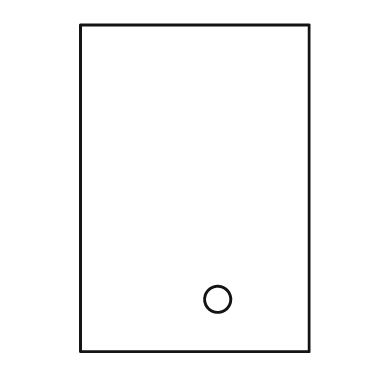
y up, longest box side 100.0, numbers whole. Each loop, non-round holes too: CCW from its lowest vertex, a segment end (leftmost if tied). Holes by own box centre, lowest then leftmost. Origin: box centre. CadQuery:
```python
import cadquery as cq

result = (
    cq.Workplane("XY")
    .moveTo(-35.0, -50.0)
    .lineTo(35.0, -50.0)
    .lineTo(35.0, 50.0)
    .lineTo(-35.0, 50.0)
    .close()
    .moveTo(7.0, -34.0)
    .circle(4.0)
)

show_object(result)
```